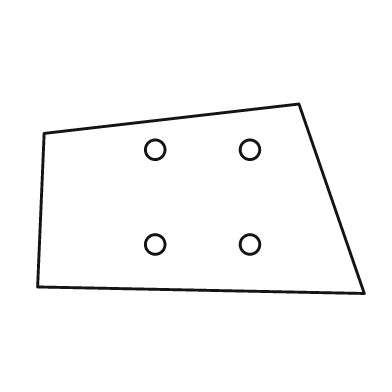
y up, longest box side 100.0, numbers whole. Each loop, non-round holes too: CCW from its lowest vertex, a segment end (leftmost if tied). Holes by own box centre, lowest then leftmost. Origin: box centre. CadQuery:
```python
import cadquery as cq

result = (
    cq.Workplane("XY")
    .moveTo(50.0, -29.0)
    .lineTo(30.0, 29.0)
    .lineTo(-48.0, 20.0)
    .lineTo(-50.0, -27.0)
    .close()
    .moveTo(-14.0, -14.0)
    .circle(3.0)
    .moveTo(15.0, -14.0)
    .circle(3.0)
    .moveTo(-14.0, 15.0)
    .circle(3.0)
    .moveTo(15.0, 15.0)
    .circle(3.0)
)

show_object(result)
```